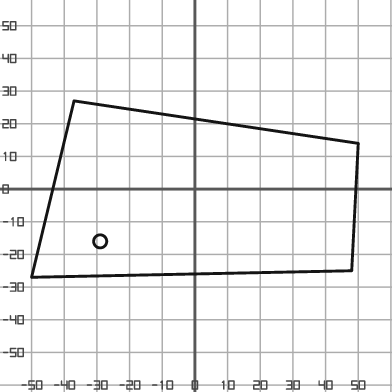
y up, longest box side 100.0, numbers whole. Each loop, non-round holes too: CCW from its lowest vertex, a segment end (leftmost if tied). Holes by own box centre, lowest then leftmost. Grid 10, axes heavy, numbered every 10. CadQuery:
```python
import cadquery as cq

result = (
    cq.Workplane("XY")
    .moveTo(-50.0, -27.0)
    .lineTo(48.0, -25.0)
    .lineTo(50.0, 14.0)
    .lineTo(-37.0, 27.0)
    .close()
    .moveTo(-29.0, -16.0)
    .circle(2.0)
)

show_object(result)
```